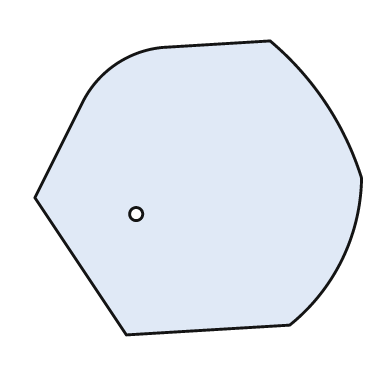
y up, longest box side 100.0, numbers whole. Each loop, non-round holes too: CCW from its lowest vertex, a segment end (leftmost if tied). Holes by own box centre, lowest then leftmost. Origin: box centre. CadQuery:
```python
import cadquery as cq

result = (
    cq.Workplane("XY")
    .moveTo(-22.0, -45.0)
    .lineTo(28.0, -42.0)
    .threePointArc((44.0, -22.0), (50.0, 3.0))
    .threePointArc((39.0, 26.0), (22.0, 45.0))
    .lineTo(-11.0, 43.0)
    .threePointArc((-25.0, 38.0), (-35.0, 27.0))
    .lineTo(-50.0, -3.0)
    .close()
    .moveTo(-19.0, -8.0)
    .circle(2.0)
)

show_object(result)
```